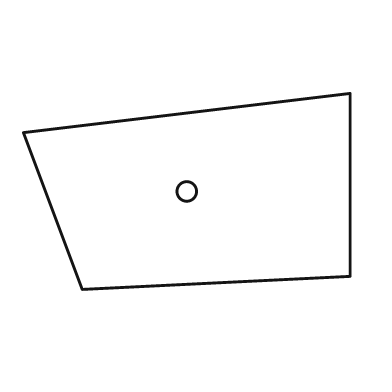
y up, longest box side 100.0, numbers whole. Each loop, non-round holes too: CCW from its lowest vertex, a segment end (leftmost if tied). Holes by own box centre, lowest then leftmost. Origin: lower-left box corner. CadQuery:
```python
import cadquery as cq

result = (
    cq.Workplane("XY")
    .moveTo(18.0, 0.0)
    .lineTo(100.0, 4.0)
    .lineTo(100.0, 60.0)
    .lineTo(0.0, 48.0)
    .close()
    .moveTo(50.0, 30.0)
    .circle(3.0)
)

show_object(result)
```